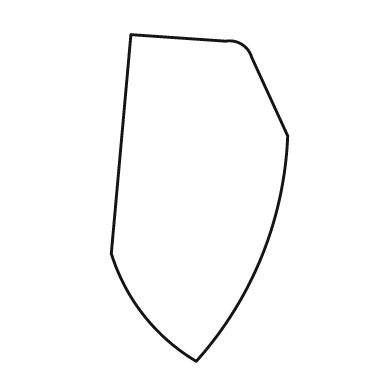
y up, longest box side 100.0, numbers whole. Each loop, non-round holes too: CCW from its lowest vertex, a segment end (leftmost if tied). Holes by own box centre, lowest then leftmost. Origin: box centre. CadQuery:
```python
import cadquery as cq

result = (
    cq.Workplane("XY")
    .moveTo(-1.0, -50.0)
    .threePointArc((19.0, -18.0), (27.0, 19.0))
    .lineTo(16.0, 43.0)
    .threePointArc((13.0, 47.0), (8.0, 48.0))
    .lineTo(-21.0, 50.0)
    .lineTo(-27.0, -17.0)
    .threePointArc((-17.0, -36.0), (-1.0, -50.0))
    .close()
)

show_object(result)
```